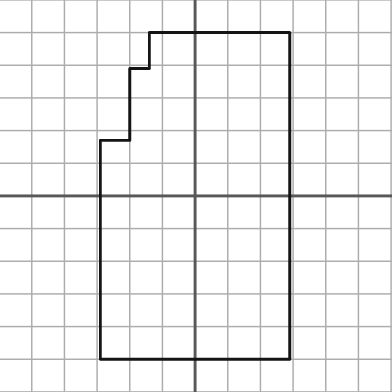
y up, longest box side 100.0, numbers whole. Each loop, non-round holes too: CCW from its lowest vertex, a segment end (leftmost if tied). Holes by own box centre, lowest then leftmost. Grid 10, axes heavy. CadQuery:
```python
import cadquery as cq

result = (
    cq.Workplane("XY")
    .moveTo(-29.0, -50.0)
    .lineTo(29.0, -50.0)
    .lineTo(29.0, 50.0)
    .lineTo(-14.0, 50.0)
    .lineTo(-14.0, 39.0)
    .lineTo(-20.0, 39.0)
    .lineTo(-20.0, 17.0)
    .lineTo(-29.0, 17.0)
    .close()
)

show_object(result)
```